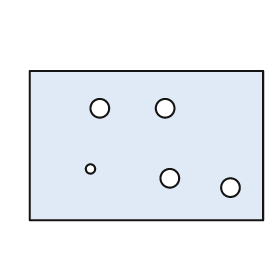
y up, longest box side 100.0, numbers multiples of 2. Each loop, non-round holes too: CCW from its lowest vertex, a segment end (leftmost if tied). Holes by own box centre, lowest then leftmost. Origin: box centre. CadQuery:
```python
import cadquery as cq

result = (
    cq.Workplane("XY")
    .moveTo(-50.0, -32.0)
    .lineTo(50.0, -32.0)
    .lineTo(50.0, 32.0)
    .lineTo(-50.0, 32.0)
    .close()
    .moveTo(36.0, -18.0)
    .circle(4.0)
    .moveTo(10.0, -14.0)
    .circle(4.0)
    .moveTo(-24.0, -10.0)
    .circle(2.0)
    .moveTo(-20.0, 16.0)
    .circle(4.0)
    .moveTo(8.0, 16.0)
    .circle(4.0)
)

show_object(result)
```